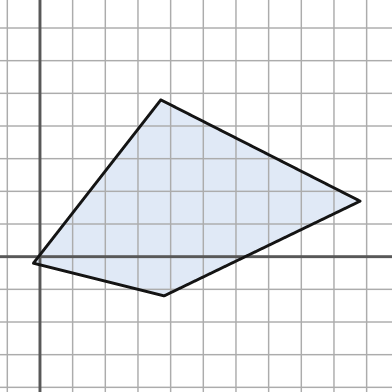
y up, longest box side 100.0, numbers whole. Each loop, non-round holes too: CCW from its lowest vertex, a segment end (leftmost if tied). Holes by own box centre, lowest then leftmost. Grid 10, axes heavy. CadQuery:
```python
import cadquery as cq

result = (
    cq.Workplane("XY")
    .moveTo(38.0, -12.0)
    .lineTo(98.0, 17.0)
    .lineTo(37.0, 48.0)
    .lineTo(-2.0, -2.0)
    .close()
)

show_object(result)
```